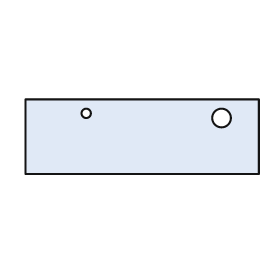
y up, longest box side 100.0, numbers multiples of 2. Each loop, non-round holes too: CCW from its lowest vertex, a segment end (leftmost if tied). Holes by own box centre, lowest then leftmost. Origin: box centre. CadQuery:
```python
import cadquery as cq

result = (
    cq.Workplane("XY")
    .moveTo(-50.0, -16.0)
    .lineTo(50.0, -16.0)
    .lineTo(50.0, 16.0)
    .lineTo(-50.0, 16.0)
    .close()
    .moveTo(34.0, 8.0)
    .circle(4.0)
    .moveTo(-24.0, 10.0)
    .circle(2.0)
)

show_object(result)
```